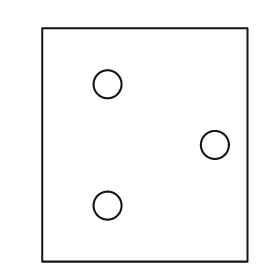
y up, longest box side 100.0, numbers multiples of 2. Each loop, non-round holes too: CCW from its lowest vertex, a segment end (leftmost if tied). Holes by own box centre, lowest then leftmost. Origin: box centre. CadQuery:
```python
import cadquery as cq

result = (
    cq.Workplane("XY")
    .moveTo(-44.0, -50.0)
    .lineTo(44.0, -50.0)
    .lineTo(44.0, 50.0)
    .lineTo(-44.0, 50.0)
    .close()
    .moveTo(-16.0, -26.0)
    .circle(6.0)
    .moveTo(30.0, 0.0)
    .circle(6.0)
    .moveTo(-16.0, 26.0)
    .circle(6.0)
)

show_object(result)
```